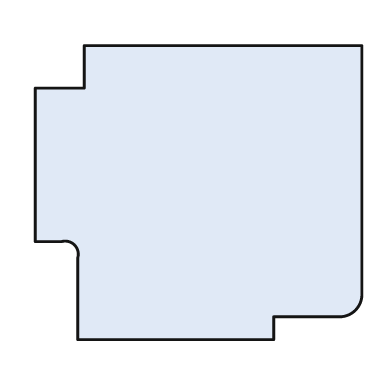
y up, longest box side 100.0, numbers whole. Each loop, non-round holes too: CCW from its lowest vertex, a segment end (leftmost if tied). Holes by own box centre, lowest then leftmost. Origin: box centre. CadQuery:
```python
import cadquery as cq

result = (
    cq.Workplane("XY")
    .moveTo(-37.0, -45.0)
    .lineTo(23.0, -45.0)
    .lineTo(23.0, -38.0)
    .lineTo(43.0, -38.0)
    .threePointArc((48.0, -36.0), (50.0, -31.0))
    .lineTo(50.0, 45.0)
    .lineTo(-35.0, 45.0)
    .lineTo(-35.0, 32.0)
    .lineTo(-50.0, 32.0)
    .lineTo(-50.0, -15.0)
    .lineTo(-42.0, -15.0)
    .threePointArc((-38.0, -16.0), (-37.0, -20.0))
    .close()
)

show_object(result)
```